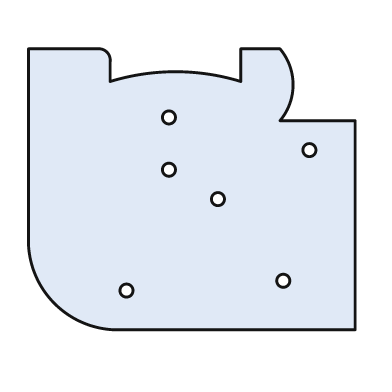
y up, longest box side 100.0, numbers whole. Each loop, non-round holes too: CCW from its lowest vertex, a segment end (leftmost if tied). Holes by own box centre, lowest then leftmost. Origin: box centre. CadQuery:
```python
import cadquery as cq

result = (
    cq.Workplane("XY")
    .moveTo(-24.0, -43.0)
    .lineTo(50.0, -43.0)
    .lineTo(50.0, 21.0)
    .lineTo(27.0, 21.0)
    .threePointArc((31.0, 32.0), (27.0, 43.0))
    .lineTo(15.0, 43.0)
    .lineTo(15.0, 33.0)
    .threePointArc((-5.0, 36.0), (-25.0, 33.0))
    .lineTo(-25.0, 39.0)
    .threePointArc((-26.0, 42.0), (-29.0, 43.0))
    .lineTo(-50.0, 43.0)
    .lineTo(-50.0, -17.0)
    .threePointArc((-42.0, -35.0), (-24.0, -43.0))
    .close()
    .moveTo(-20.0, -31.0)
    .circle(2.0)
    .moveTo(28.0, -28.0)
    .circle(2.0)
    .moveTo(8.0, -3.0)
    .circle(2.0)
    .moveTo(-7.0, 6.0)
    .circle(2.0)
    .moveTo(36.0, 12.0)
    .circle(2.0)
    .moveTo(-7.0, 22.0)
    .circle(2.0)
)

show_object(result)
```